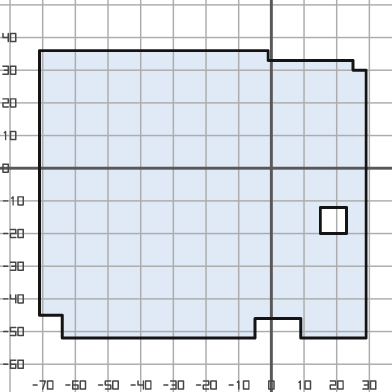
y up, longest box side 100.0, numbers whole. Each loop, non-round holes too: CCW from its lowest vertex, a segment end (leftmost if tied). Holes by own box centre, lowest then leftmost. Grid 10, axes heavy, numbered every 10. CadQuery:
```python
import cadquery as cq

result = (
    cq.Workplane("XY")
    .moveTo(-64.0, -52.0)
    .lineTo(-5.0, -52.0)
    .lineTo(-5.0, -46.0)
    .lineTo(9.0, -46.0)
    .lineTo(9.0, -52.0)
    .lineTo(29.0, -52.0)
    .lineTo(29.0, 30.0)
    .lineTo(25.0, 30.0)
    .lineTo(25.0, 33.0)
    .lineTo(-1.0, 33.0)
    .lineTo(-1.0, 36.0)
    .lineTo(-71.0, 36.0)
    .lineTo(-71.0, -45.0)
    .lineTo(-64.0, -45.0)
    .close()
    .moveTo(15.0, -20.0)
    .lineTo(23.0, -20.0)
    .lineTo(23.0, -12.0)
    .lineTo(15.0, -12.0)
    .close()
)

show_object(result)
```